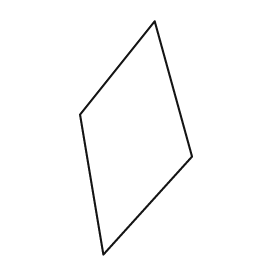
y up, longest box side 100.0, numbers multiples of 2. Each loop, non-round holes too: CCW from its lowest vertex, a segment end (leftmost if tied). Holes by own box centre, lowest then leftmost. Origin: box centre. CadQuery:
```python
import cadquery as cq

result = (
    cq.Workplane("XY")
    .moveTo(-14.0, -50.0)
    .lineTo(24.0, -8.0)
    .lineTo(8.0, 50.0)
    .lineTo(-24.0, 10.0)
    .close()
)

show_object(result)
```